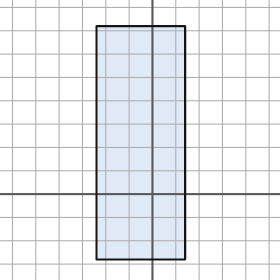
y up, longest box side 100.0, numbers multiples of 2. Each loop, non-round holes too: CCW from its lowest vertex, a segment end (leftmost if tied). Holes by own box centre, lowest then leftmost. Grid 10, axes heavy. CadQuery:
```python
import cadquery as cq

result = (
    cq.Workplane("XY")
    .moveTo(-24.0, -28.0)
    .lineTo(14.0, -28.0)
    .lineTo(14.0, 72.0)
    .lineTo(-24.0, 72.0)
    .close()
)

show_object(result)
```